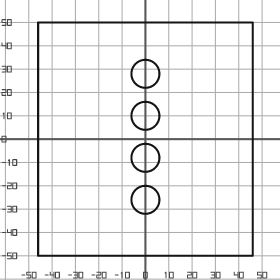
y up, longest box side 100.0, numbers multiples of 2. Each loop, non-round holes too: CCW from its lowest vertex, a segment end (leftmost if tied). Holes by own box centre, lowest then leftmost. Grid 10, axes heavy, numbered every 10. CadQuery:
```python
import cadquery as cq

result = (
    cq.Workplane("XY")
    .moveTo(-46.0, -50.0)
    .lineTo(46.0, -50.0)
    .lineTo(46.0, 50.0)
    .lineTo(-46.0, 50.0)
    .close()
    .moveTo(0.0, -26.0)
    .circle(6.0)
    .moveTo(0.0, -8.0)
    .circle(6.0)
    .moveTo(0.0, 10.0)
    .circle(6.0)
    .moveTo(0.0, 28.0)
    .circle(6.0)
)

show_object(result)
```